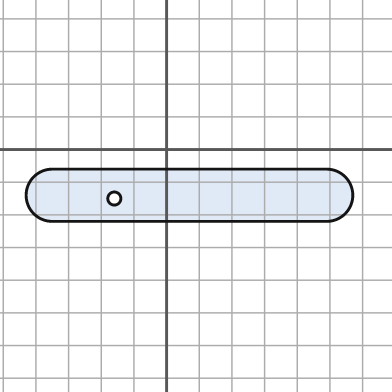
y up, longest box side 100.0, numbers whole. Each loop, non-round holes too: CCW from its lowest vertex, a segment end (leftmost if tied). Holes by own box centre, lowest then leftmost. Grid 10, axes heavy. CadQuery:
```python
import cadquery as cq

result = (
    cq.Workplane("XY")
    .moveTo(-35.0, -22.0)
    .lineTo(49.0, -22.0)
    .threePointArc((57.0, -14.0), (49.0, -6.0))
    .lineTo(-35.0, -6.0)
    .threePointArc((-43.0, -14.0), (-35.0, -22.0))
    .close()
    .moveTo(-16.0, -15.0)
    .circle(2.0)
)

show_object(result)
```